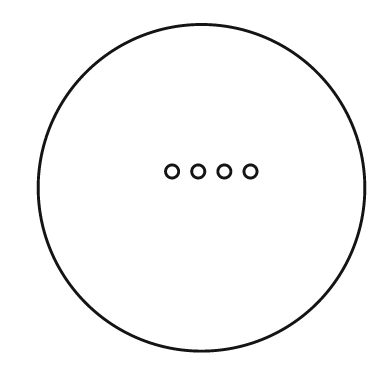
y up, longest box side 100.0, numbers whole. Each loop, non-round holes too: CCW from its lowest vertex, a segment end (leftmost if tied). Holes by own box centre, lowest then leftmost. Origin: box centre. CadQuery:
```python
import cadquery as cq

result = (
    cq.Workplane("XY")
    .moveTo(0.0, 0.0)
    .circle(50.0)
    .moveTo(-9.0, 5.0)
    .circle(2.0)
    .moveTo(-1.0, 5.0)
    .circle(2.0)
    .moveTo(7.0, 5.0)
    .circle(2.0)
    .moveTo(15.0, 5.0)
    .circle(2.0)
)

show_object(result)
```